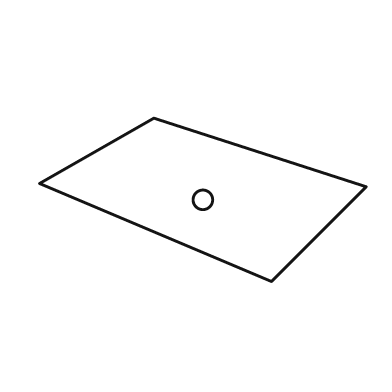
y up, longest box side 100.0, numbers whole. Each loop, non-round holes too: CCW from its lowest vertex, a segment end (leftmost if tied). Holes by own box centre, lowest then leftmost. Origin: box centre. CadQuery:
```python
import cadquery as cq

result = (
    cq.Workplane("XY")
    .moveTo(21.0, -25.0)
    .lineTo(50.0, 4.0)
    .lineTo(-15.0, 25.0)
    .lineTo(-50.0, 5.0)
    .close()
    .moveTo(0.0, 0.0)
    .circle(3.0)
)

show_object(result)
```